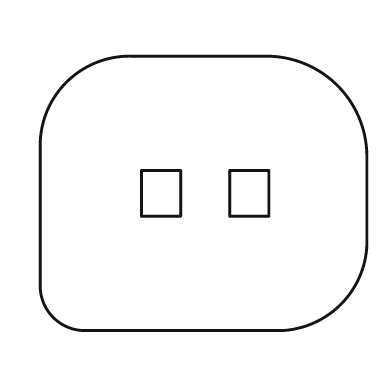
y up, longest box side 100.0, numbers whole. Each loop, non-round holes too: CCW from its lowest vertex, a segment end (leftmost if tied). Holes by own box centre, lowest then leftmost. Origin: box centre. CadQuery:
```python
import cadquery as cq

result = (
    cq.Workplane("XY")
    .moveTo(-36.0, -42.0)
    .lineTo(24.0, -42.0)
    .threePointArc((42.0, -34.0), (50.0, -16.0))
    .lineTo(50.0, 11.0)
    .threePointArc((41.0, 33.0), (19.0, 42.0))
    .lineTo(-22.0, 42.0)
    .threePointArc((-42.0, 34.0), (-50.0, 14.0))
    .lineTo(-50.0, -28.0)
    .threePointArc((-46.0, -38.0), (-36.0, -42.0))
    .close()
    .moveTo(-19.0, -7.0)
    .lineTo(-7.0, -7.0)
    .lineTo(-7.0, 7.0)
    .lineTo(-19.0, 7.0)
    .close()
    .moveTo(8.0, -7.0)
    .lineTo(20.0, -7.0)
    .lineTo(20.0, 7.0)
    .lineTo(8.0, 7.0)
    .close()
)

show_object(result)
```